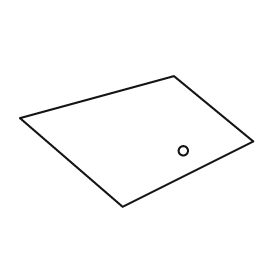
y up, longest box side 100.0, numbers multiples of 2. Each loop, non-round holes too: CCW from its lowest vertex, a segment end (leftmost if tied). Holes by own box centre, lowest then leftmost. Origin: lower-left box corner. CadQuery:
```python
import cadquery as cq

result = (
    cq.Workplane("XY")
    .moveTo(44.0, 0.0)
    .lineTo(100.0, 28.0)
    .lineTo(66.0, 56.0)
    .lineTo(0.0, 38.0)
    .close()
    .moveTo(70.0, 24.0)
    .circle(2.0)
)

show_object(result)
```